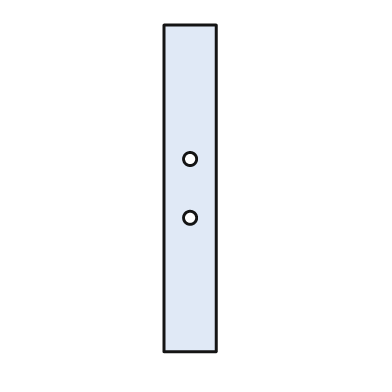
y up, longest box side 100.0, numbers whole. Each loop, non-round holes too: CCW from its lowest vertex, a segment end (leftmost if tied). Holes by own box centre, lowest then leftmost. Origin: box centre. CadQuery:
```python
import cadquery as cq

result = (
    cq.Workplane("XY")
    .moveTo(-8.0, -50.0)
    .lineTo(8.0, -50.0)
    .lineTo(8.0, 50.0)
    .lineTo(-8.0, 50.0)
    .close()
    .moveTo(0.0, -9.0)
    .circle(2.0)
    .moveTo(0.0, 9.0)
    .circle(2.0)
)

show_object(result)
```